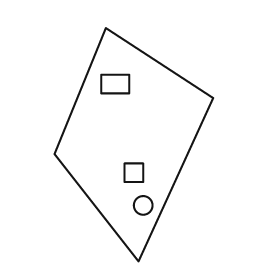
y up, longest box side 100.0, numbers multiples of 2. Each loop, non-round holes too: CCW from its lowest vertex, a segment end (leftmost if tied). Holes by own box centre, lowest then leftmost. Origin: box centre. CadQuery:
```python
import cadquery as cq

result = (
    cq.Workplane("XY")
    .moveTo(2.0, -50.0)
    .lineTo(34.0, 20.0)
    .lineTo(-12.0, 50.0)
    .lineTo(-34.0, -4.0)
    .close()
    .moveTo(4.0, -26.0)
    .circle(4.0)
    .moveTo(-4.0, -16.0)
    .lineTo(4.0, -16.0)
    .lineTo(4.0, -8.0)
    .lineTo(-4.0, -8.0)
    .close()
    .moveTo(-14.0, 22.0)
    .lineTo(-2.0, 22.0)
    .lineTo(-2.0, 30.0)
    .lineTo(-14.0, 30.0)
    .close()
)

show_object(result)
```